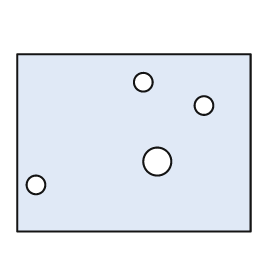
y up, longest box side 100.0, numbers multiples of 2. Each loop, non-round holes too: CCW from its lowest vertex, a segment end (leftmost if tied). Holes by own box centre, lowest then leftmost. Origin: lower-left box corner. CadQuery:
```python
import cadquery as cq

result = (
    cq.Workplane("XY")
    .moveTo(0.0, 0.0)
    .lineTo(100.0, 0.0)
    .lineTo(100.0, 76.0)
    .lineTo(0.0, 76.0)
    .close()
    .moveTo(8.0, 20.0)
    .circle(4.0)
    .moveTo(60.0, 30.0)
    .circle(6.0)
    .moveTo(80.0, 54.0)
    .circle(4.0)
    .moveTo(54.0, 64.0)
    .circle(4.0)
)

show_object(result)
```